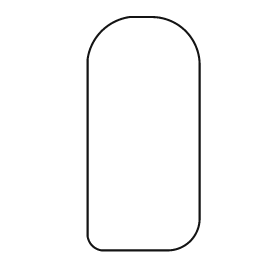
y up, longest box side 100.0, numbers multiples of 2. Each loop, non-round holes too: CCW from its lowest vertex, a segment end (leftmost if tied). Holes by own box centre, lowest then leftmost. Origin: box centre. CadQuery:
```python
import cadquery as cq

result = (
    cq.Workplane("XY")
    .moveTo(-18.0, -50.0)
    .lineTo(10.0, -50.0)
    .threePointArc((20.0, -46.0), (24.0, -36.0))
    .lineTo(24.0, 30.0)
    .threePointArc((18.0, 44.0), (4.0, 50.0))
    .lineTo(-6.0, 50.0)
    .threePointArc((-18.0, 44.0), (-24.0, 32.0))
    .lineTo(-24.0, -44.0)
    .threePointArc((-22.0, -48.0), (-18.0, -50.0))
    .close()
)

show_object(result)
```